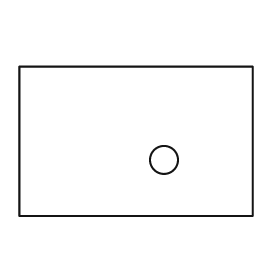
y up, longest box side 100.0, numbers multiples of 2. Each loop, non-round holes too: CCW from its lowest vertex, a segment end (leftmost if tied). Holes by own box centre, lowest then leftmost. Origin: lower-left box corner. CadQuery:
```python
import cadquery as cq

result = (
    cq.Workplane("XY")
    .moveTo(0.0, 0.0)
    .lineTo(100.0, 0.0)
    .lineTo(100.0, 64.0)
    .lineTo(0.0, 64.0)
    .close()
    .moveTo(62.0, 24.0)
    .circle(6.0)
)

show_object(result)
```